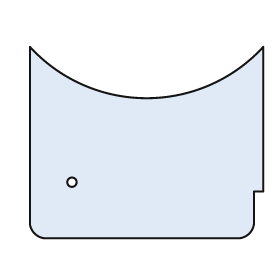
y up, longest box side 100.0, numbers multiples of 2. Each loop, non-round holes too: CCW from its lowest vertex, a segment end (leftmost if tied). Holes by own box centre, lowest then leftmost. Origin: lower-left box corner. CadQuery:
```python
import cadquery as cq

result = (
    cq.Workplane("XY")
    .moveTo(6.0, 0.0)
    .lineTo(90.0, 0.0)
    .threePointArc((94.0, 2.0), (96.0, 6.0))
    .lineTo(96.0, 20.0)
    .lineTo(100.0, 20.0)
    .lineTo(100.0, 82.0)
    .threePointArc((50.0, 60.0), (0.0, 82.0))
    .lineTo(0.0, 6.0)
    .threePointArc((2.0, 2.0), (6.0, 0.0))
    .close()
    .moveTo(18.0, 24.0)
    .circle(2.0)
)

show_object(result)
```